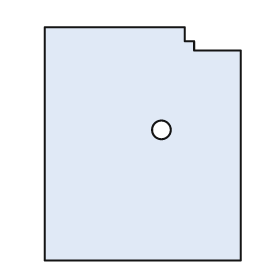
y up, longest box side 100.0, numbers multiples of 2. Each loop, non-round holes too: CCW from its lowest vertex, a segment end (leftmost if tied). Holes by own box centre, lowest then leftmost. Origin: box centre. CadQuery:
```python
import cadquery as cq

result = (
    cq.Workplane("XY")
    .moveTo(-42.0, -50.0)
    .lineTo(42.0, -50.0)
    .lineTo(42.0, 40.0)
    .lineTo(22.0, 40.0)
    .lineTo(22.0, 44.0)
    .lineTo(18.0, 44.0)
    .lineTo(18.0, 50.0)
    .lineTo(-42.0, 50.0)
    .close()
    .moveTo(8.0, 6.0)
    .circle(4.0)
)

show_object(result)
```